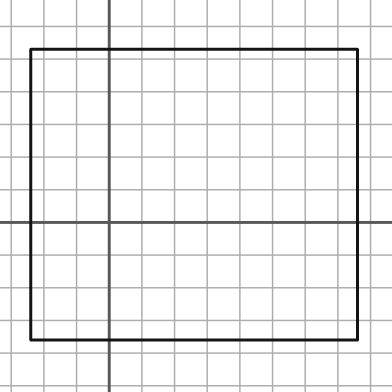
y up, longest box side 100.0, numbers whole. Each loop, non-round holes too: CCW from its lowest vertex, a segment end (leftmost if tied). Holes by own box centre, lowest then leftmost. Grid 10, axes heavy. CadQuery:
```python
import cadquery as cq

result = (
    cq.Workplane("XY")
    .moveTo(-24.0, -36.0)
    .lineTo(76.0, -36.0)
    .lineTo(76.0, 53.0)
    .lineTo(-24.0, 53.0)
    .close()
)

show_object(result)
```